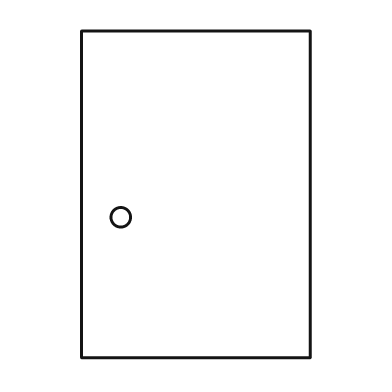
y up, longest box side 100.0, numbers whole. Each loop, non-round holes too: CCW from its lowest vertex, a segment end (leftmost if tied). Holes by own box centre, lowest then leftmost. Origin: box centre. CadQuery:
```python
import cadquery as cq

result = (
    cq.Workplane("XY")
    .moveTo(-35.0, -50.0)
    .lineTo(35.0, -50.0)
    .lineTo(35.0, 50.0)
    .lineTo(-35.0, 50.0)
    .close()
    .moveTo(-23.0, -7.0)
    .circle(3.0)
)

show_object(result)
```